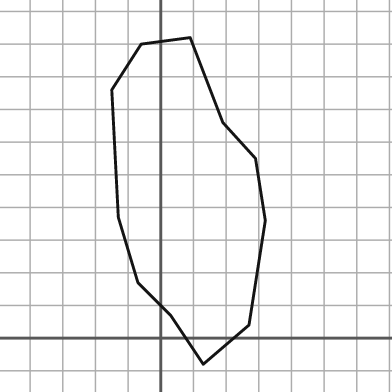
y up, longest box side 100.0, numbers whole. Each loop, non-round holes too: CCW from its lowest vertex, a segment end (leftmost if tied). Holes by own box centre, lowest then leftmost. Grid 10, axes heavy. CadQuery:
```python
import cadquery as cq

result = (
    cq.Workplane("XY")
    .moveTo(13.0, -8.0)
    .lineTo(27.0, 4.0)
    .lineTo(32.0, 36.0)
    .lineTo(29.0, 55.0)
    .lineTo(19.0, 66.0)
    .lineTo(9.0, 92.0)
    .lineTo(-6.0, 90.0)
    .lineTo(-15.0, 76.0)
    .lineTo(-13.0, 37.0)
    .lineTo(-7.0, 17.0)
    .lineTo(3.0, 7.0)
    .close()
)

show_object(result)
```